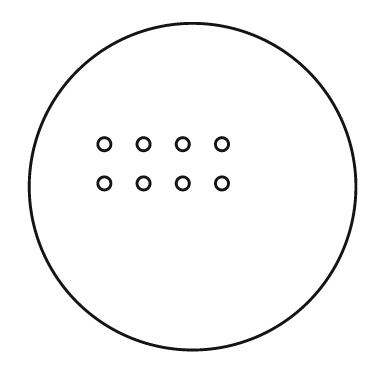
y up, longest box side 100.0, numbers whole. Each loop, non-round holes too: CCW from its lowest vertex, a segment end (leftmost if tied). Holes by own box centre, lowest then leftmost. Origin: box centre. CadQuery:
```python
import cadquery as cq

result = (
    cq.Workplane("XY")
    .moveTo(0.0, 0.0)
    .circle(50.0)
    .moveTo(-27.0, 1.0)
    .circle(2.0)
    .moveTo(-15.0, 1.0)
    .circle(2.0)
    .moveTo(-3.0, 1.0)
    .circle(2.0)
    .moveTo(9.0, 1.0)
    .circle(2.0)
    .moveTo(-27.0, 13.0)
    .circle(2.0)
    .moveTo(-15.0, 13.0)
    .circle(2.0)
    .moveTo(-3.0, 13.0)
    .circle(2.0)
    .moveTo(9.0, 13.0)
    .circle(2.0)
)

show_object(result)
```